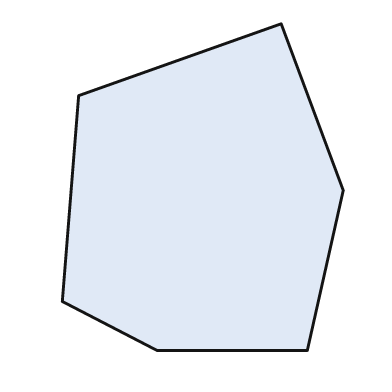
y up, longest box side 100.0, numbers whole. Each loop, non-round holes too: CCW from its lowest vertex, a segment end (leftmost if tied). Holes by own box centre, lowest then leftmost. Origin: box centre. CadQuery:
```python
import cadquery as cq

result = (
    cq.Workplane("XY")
    .moveTo(-14.0, -50.0)
    .lineTo(32.0, -50.0)
    .lineTo(43.0, -1.0)
    .lineTo(24.0, 50.0)
    .lineTo(-38.0, 28.0)
    .lineTo(-43.0, -35.0)
    .close()
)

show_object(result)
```